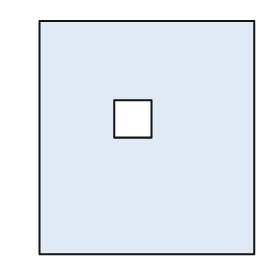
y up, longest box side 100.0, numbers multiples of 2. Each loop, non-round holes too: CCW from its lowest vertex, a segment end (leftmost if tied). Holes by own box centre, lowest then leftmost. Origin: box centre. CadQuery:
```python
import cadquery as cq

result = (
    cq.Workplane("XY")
    .moveTo(-46.0, -50.0)
    .lineTo(46.0, -50.0)
    .lineTo(46.0, 50.0)
    .lineTo(-46.0, 50.0)
    .close()
    .moveTo(-14.0, 0.0)
    .lineTo(2.0, 0.0)
    .lineTo(2.0, 16.0)
    .lineTo(-14.0, 16.0)
    .close()
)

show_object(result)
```